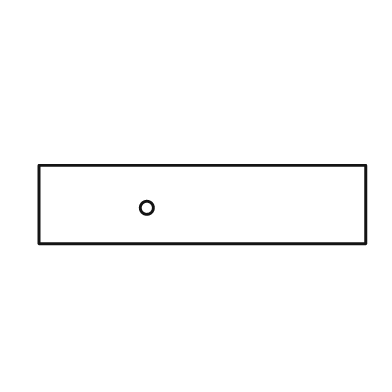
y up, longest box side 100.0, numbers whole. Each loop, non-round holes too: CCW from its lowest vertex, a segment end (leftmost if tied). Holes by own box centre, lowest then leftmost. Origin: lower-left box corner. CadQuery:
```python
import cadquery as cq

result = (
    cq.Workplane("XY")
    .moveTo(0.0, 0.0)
    .lineTo(100.0, 0.0)
    .lineTo(100.0, 24.0)
    .lineTo(0.0, 24.0)
    .close()
    .moveTo(33.0, 11.0)
    .circle(2.0)
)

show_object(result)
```